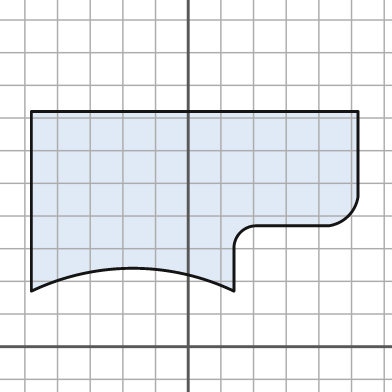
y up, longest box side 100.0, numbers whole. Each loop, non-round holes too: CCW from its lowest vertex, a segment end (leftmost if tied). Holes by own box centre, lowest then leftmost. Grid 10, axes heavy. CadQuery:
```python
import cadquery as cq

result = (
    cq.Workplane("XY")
    .moveTo(-48.0, 17.0)
    .threePointArc((-17.0, 24.0), (14.0, 17.0))
    .lineTo(14.0, 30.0)
    .threePointArc((16.0, 35.0), (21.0, 37.0))
    .lineTo(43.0, 37.0)
    .threePointArc((49.0, 40.0), (52.0, 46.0))
    .lineTo(52.0, 72.0)
    .lineTo(-48.0, 72.0)
    .close()
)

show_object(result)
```